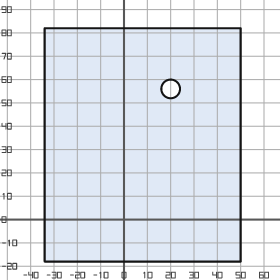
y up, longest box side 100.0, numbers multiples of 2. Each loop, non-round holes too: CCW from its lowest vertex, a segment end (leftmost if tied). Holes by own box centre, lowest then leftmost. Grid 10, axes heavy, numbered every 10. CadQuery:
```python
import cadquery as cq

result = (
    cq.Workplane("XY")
    .moveTo(-34.0, -18.0)
    .lineTo(50.0, -18.0)
    .lineTo(50.0, 82.0)
    .lineTo(-34.0, 82.0)
    .close()
    .moveTo(20.0, 56.0)
    .circle(4.0)
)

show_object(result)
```